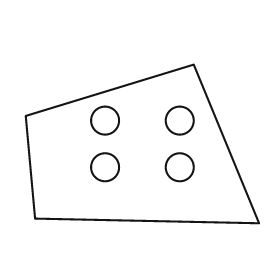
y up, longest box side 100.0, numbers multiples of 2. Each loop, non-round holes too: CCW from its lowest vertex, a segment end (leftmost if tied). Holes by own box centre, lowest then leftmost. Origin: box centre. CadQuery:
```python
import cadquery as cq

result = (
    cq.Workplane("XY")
    .moveTo(50.0, -34.0)
    .lineTo(22.0, 34.0)
    .lineTo(-50.0, 12.0)
    .lineTo(-46.0, -32.0)
    .close()
    .moveTo(-16.0, -10.0)
    .circle(6.0)
    .moveTo(16.0, -10.0)
    .circle(6.0)
    .moveTo(-16.0, 10.0)
    .circle(6.0)
    .moveTo(16.0, 10.0)
    .circle(6.0)
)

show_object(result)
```